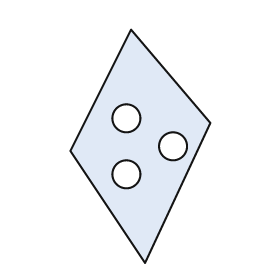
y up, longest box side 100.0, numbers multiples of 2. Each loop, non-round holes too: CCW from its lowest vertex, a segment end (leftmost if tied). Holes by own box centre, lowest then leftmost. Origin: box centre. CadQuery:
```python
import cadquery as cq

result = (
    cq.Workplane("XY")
    .moveTo(2.0, -50.0)
    .lineTo(30.0, 10.0)
    .lineTo(-4.0, 50.0)
    .lineTo(-30.0, -2.0)
    .close()
    .moveTo(-6.0, -12.0)
    .circle(6.0)
    .moveTo(14.0, 0.0)
    .circle(6.0)
    .moveTo(-6.0, 12.0)
    .circle(6.0)
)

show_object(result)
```